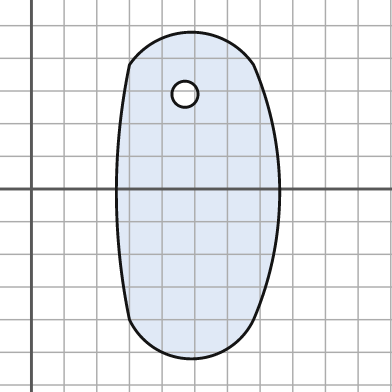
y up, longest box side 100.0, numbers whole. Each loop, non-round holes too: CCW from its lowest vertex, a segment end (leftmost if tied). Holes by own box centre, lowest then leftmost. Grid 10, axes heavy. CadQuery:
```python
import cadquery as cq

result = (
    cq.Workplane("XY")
    .moveTo(30.0, -40.0)
    .threePointArc((49.0, -52.0), (68.0, -40.0))
    .threePointArc((76.0, -1.0), (68.0, 38.0))
    .threePointArc((49.0, 48.0), (30.0, 38.0))
    .threePointArc((26.0, -1.0), (30.0, -40.0))
    .close()
    .moveTo(47.0, 29.0)
    .circle(4.0)
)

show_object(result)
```